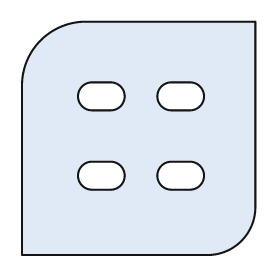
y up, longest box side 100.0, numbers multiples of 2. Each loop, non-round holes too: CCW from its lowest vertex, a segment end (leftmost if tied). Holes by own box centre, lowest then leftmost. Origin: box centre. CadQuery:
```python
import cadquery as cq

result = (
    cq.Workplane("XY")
    .moveTo(-50.0, -50.0)
    .lineTo(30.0, -50.0)
    .threePointArc((44.0, -44.0), (50.0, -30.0))
    .lineTo(50.0, 50.0)
    .lineTo(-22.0, 50.0)
    .threePointArc((-42.0, 42.0), (-50.0, 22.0))
    .close()
    .moveTo(-20.0, -22.0)
    .lineTo(-12.0, -22.0)
    .threePointArc((-6.0, -16.0), (-12.0, -10.0))
    .lineTo(-20.0, -10.0)
    .threePointArc((-26.0, -16.0), (-20.0, -22.0))
    .close()
    .moveTo(14.0, -22.0)
    .lineTo(22.0, -22.0)
    .threePointArc((28.0, -16.0), (22.0, -10.0))
    .lineTo(14.0, -10.0)
    .threePointArc((8.0, -16.0), (14.0, -22.0))
    .close()
    .moveTo(-20.0, 12.0)
    .lineTo(-12.0, 12.0)
    .threePointArc((-6.0, 18.0), (-12.0, 24.0))
    .lineTo(-20.0, 24.0)
    .threePointArc((-26.0, 18.0), (-20.0, 12.0))
    .close()
    .moveTo(14.0, 12.0)
    .lineTo(22.0, 12.0)
    .threePointArc((28.0, 18.0), (22.0, 24.0))
    .lineTo(14.0, 24.0)
    .threePointArc((8.0, 18.0), (14.0, 12.0))
    .close()
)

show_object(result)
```